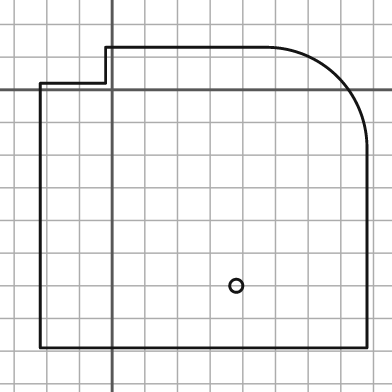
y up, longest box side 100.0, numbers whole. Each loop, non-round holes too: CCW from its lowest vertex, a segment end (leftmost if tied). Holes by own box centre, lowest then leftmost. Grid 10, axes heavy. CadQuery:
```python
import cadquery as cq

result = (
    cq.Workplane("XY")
    .moveTo(-22.0, -79.0)
    .lineTo(78.0, -79.0)
    .lineTo(78.0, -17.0)
    .threePointArc((69.0, 4.0), (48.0, 13.0))
    .lineTo(-2.0, 13.0)
    .lineTo(-2.0, 2.0)
    .lineTo(-22.0, 2.0)
    .close()
    .moveTo(38.0, -60.0)
    .circle(2.0)
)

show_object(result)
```